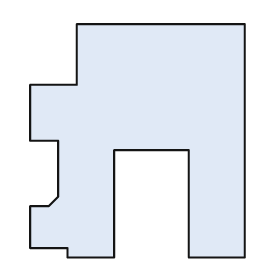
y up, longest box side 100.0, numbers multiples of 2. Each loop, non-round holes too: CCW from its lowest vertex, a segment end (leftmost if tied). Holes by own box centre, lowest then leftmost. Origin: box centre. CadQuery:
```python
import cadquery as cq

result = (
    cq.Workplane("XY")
    .moveTo(-30.0, -50.0)
    .lineTo(-10.0, -50.0)
    .lineTo(-10.0, -4.0)
    .lineTo(22.0, -4.0)
    .lineTo(22.0, -50.0)
    .lineTo(46.0, -50.0)
    .lineTo(46.0, 50.0)
    .lineTo(-26.0, 50.0)
    .lineTo(-26.0, 24.0)
    .lineTo(-46.0, 24.0)
    .lineTo(-46.0, 0.0)
    .lineTo(-34.0, 0.0)
    .lineTo(-34.0, -24.0)
    .lineTo(-38.0, -28.0)
    .lineTo(-46.0, -28.0)
    .lineTo(-46.0, -46.0)
    .lineTo(-30.0, -46.0)
    .close()
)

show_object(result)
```